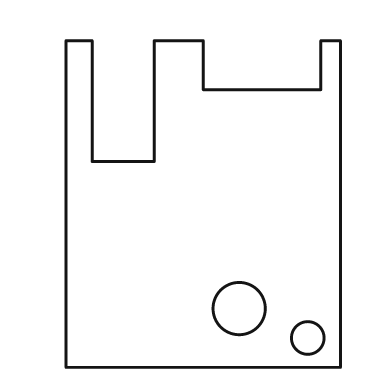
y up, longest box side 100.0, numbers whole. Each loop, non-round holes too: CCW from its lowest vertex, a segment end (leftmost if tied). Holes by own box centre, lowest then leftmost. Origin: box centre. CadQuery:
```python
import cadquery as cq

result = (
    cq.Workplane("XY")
    .moveTo(-42.0, -50.0)
    .lineTo(42.0, -50.0)
    .lineTo(42.0, 50.0)
    .lineTo(36.0, 50.0)
    .lineTo(36.0, 35.0)
    .lineTo(0.0, 35.0)
    .lineTo(0.0, 50.0)
    .lineTo(-15.0, 50.0)
    .lineTo(-15.0, 13.0)
    .lineTo(-34.0, 13.0)
    .lineTo(-34.0, 50.0)
    .lineTo(-42.0, 50.0)
    .close()
    .moveTo(32.0, -41.0)
    .circle(5.0)
    .moveTo(11.0, -32.0)
    .circle(8.0)
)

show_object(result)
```